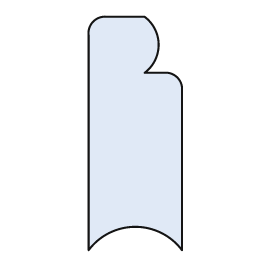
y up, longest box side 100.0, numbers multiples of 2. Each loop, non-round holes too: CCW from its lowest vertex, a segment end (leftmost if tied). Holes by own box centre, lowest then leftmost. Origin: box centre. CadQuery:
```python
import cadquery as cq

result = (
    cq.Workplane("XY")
    .moveTo(-20.0, -50.0)
    .threePointArc((0.0, -40.0), (20.0, -50.0))
    .lineTo(20.0, 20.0)
    .threePointArc((18.0, 24.0), (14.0, 26.0))
    .lineTo(4.0, 26.0)
    .threePointArc((10.0, 38.0), (4.0, 50.0))
    .lineTo(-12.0, 50.0)
    .threePointArc((-18.0, 48.0), (-20.0, 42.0))
    .close()
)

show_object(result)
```